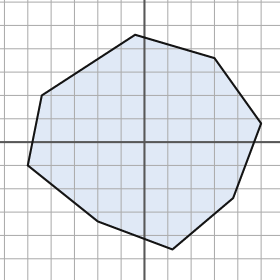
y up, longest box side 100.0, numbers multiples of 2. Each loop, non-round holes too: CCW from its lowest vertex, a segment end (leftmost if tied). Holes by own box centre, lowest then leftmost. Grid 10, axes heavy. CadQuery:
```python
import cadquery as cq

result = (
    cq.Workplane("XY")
    .moveTo(12.0, -46.0)
    .lineTo(38.0, -24.0)
    .lineTo(50.0, 8.0)
    .lineTo(30.0, 36.0)
    .lineTo(-4.0, 46.0)
    .lineTo(-44.0, 20.0)
    .lineTo(-50.0, -10.0)
    .lineTo(-20.0, -34.0)
    .close()
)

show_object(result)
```